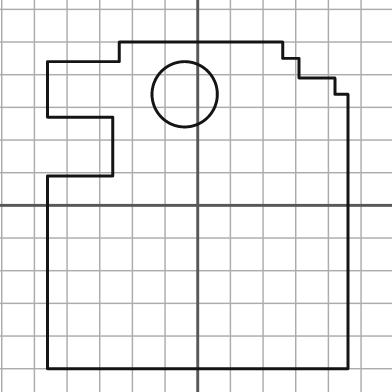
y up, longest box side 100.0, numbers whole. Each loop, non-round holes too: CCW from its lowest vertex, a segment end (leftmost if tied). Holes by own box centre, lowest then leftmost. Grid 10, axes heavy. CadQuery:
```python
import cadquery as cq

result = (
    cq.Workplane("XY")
    .moveTo(-46.0, -50.0)
    .lineTo(46.0, -50.0)
    .lineTo(46.0, 34.0)
    .lineTo(42.0, 34.0)
    .lineTo(42.0, 39.0)
    .lineTo(31.0, 39.0)
    .lineTo(31.0, 45.0)
    .lineTo(26.0, 45.0)
    .lineTo(26.0, 50.0)
    .lineTo(-24.0, 50.0)
    .lineTo(-24.0, 44.0)
    .lineTo(-46.0, 44.0)
    .lineTo(-46.0, 27.0)
    .lineTo(-26.0, 27.0)
    .lineTo(-26.0, 9.0)
    .lineTo(-46.0, 9.0)
    .close()
    .moveTo(-4.0, 34.0)
    .circle(10.0)
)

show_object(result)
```